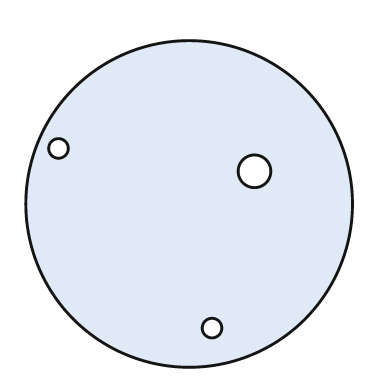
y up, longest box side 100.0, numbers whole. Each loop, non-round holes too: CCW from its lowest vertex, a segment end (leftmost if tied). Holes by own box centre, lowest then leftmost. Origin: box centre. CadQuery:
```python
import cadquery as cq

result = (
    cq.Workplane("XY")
    .moveTo(0.0, 0.0)
    .circle(50.0)
    .moveTo(7.0, -38.0)
    .circle(3.0)
    .moveTo(20.0, 10.0)
    .circle(5.0)
    .moveTo(-40.0, 17.0)
    .circle(3.0)
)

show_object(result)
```